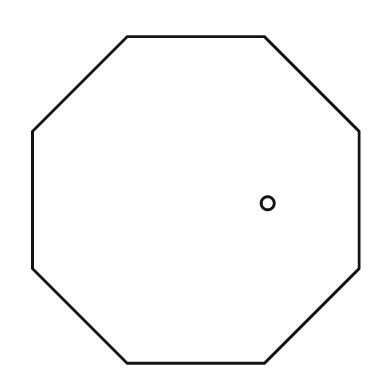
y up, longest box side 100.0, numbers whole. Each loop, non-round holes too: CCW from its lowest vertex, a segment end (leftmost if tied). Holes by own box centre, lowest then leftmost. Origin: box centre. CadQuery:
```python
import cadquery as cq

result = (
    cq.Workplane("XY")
    .moveTo(-21.0, -50.0)
    .lineTo(21.0, -50.0)
    .lineTo(50.0, -21.0)
    .lineTo(50.0, 21.0)
    .lineTo(21.0, 50.0)
    .lineTo(-21.0, 50.0)
    .lineTo(-50.0, 21.0)
    .lineTo(-50.0, -21.0)
    .close()
    .moveTo(22.0, -1.0)
    .circle(2.0)
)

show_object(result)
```